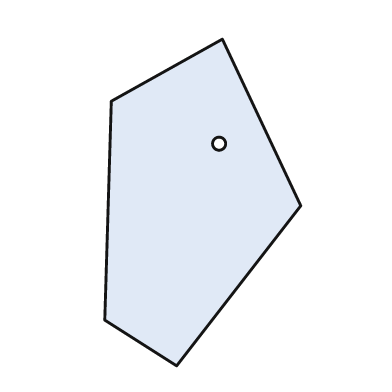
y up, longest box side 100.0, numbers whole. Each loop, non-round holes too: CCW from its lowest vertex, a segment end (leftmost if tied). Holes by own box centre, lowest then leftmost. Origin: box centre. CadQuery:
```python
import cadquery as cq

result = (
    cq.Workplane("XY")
    .moveTo(-8.0, -50.0)
    .lineTo(30.0, -1.0)
    .lineTo(6.0, 50.0)
    .lineTo(-28.0, 31.0)
    .lineTo(-30.0, -36.0)
    .close()
    .moveTo(5.0, 18.0)
    .circle(2.0)
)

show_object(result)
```